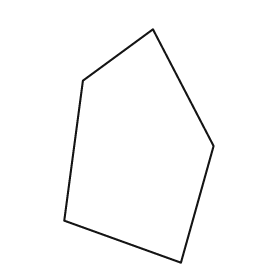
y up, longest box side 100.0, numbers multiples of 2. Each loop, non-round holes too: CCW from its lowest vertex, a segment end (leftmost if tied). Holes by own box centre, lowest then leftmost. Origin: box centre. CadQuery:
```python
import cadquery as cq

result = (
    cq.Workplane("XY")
    .moveTo(18.0, -50.0)
    .lineTo(32.0, 0.0)
    .lineTo(6.0, 50.0)
    .lineTo(-24.0, 28.0)
    .lineTo(-32.0, -32.0)
    .close()
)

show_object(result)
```